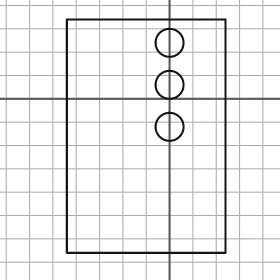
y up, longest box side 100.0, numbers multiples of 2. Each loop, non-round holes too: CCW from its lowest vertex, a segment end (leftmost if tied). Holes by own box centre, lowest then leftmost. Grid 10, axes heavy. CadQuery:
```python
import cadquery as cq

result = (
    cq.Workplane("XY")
    .moveTo(-44.0, -66.0)
    .lineTo(24.0, -66.0)
    .lineTo(24.0, 34.0)
    .lineTo(-44.0, 34.0)
    .close()
    .moveTo(0.0, -12.0)
    .circle(6.0)
    .moveTo(0.0, 6.0)
    .circle(6.0)
    .moveTo(0.0, 24.0)
    .circle(6.0)
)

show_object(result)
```